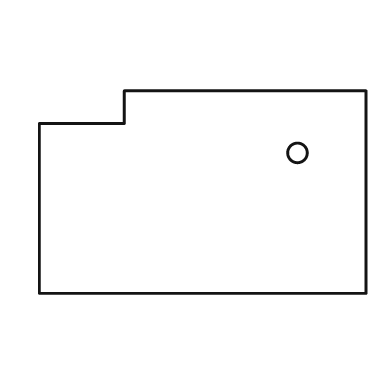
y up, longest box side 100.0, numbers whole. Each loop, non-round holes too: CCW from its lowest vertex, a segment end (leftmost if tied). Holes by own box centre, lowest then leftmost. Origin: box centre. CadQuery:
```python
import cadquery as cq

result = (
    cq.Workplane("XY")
    .moveTo(-50.0, -31.0)
    .lineTo(50.0, -31.0)
    .lineTo(50.0, 31.0)
    .lineTo(-24.0, 31.0)
    .lineTo(-24.0, 21.0)
    .lineTo(-50.0, 21.0)
    .close()
    .moveTo(29.0, 12.0)
    .circle(3.0)
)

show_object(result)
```